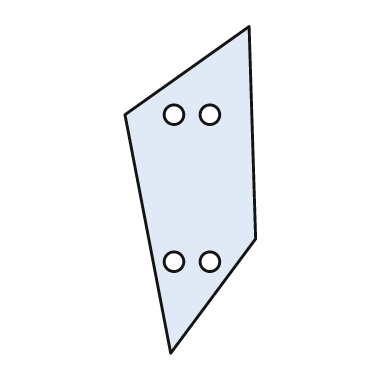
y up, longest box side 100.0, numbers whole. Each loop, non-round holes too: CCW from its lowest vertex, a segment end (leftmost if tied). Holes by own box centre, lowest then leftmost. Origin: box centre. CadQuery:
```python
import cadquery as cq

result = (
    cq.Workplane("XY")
    .moveTo(-6.0, -50.0)
    .lineTo(20.0, -15.0)
    .lineTo(18.0, 50.0)
    .lineTo(-20.0, 23.0)
    .close()
    .moveTo(-5.0, -22.0)
    .circle(3.0)
    .moveTo(6.0, -22.0)
    .circle(3.0)
    .moveTo(-5.0, 23.0)
    .circle(3.0)
    .moveTo(6.0, 23.0)
    .circle(3.0)
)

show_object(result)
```